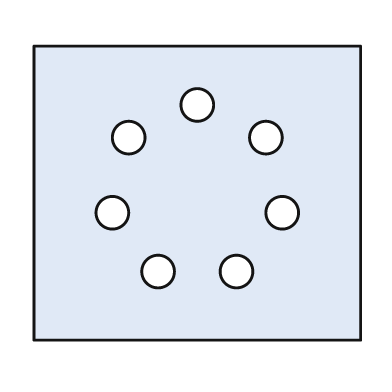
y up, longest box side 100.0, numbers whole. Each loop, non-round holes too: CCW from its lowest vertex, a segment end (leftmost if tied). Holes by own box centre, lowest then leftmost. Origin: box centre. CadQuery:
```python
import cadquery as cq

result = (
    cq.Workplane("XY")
    .moveTo(-50.0, -45.0)
    .lineTo(50.0, -45.0)
    .lineTo(50.0, 45.0)
    .lineTo(-50.0, 45.0)
    .close()
    .moveTo(-12.0, -24.0)
    .circle(5.0)
    .moveTo(12.0, -24.0)
    .circle(5.0)
    .moveTo(-26.0, -6.0)
    .circle(5.0)
    .moveTo(26.0, -6.0)
    .circle(5.0)
    .moveTo(-21.0, 17.0)
    .circle(5.0)
    .moveTo(21.0, 17.0)
    .circle(5.0)
    .moveTo(0.0, 27.0)
    .circle(5.0)
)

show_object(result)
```